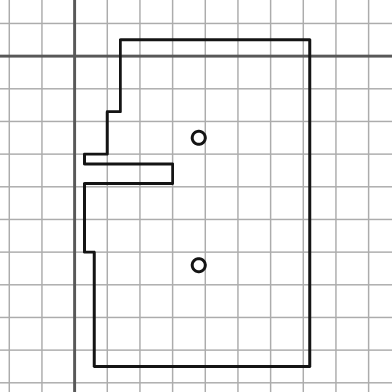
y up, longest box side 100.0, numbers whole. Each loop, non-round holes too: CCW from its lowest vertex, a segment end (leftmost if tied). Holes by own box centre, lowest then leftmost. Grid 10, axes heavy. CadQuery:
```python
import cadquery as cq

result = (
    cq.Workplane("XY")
    .moveTo(6.0, -95.0)
    .lineTo(72.0, -95.0)
    .lineTo(72.0, 5.0)
    .lineTo(14.0, 5.0)
    .lineTo(14.0, -17.0)
    .lineTo(10.0, -17.0)
    .lineTo(10.0, -30.0)
    .lineTo(3.0, -30.0)
    .lineTo(3.0, -33.0)
    .lineTo(30.0, -33.0)
    .lineTo(30.0, -39.0)
    .lineTo(3.0, -39.0)
    .lineTo(3.0, -60.0)
    .lineTo(6.0, -60.0)
    .close()
    .moveTo(38.0, -64.0)
    .circle(2.0)
    .moveTo(38.0, -25.0)
    .circle(2.0)
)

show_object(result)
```